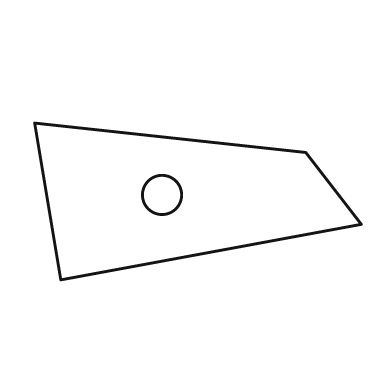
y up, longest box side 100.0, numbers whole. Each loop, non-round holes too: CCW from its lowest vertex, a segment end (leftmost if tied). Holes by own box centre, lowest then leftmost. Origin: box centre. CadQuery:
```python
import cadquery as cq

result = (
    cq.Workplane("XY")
    .moveTo(-42.0, -24.0)
    .lineTo(50.0, -7.0)
    .lineTo(33.0, 15.0)
    .lineTo(-50.0, 24.0)
    .close()
    .moveTo(-11.0, 2.0)
    .circle(6.0)
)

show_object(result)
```